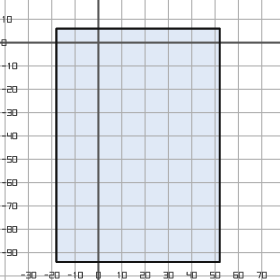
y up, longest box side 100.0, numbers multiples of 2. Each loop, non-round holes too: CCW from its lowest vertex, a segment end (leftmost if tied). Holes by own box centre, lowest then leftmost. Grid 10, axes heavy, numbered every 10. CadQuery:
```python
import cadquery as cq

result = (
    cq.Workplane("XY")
    .moveTo(-18.0, -94.0)
    .lineTo(52.0, -94.0)
    .lineTo(52.0, 6.0)
    .lineTo(-18.0, 6.0)
    .close()
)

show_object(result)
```